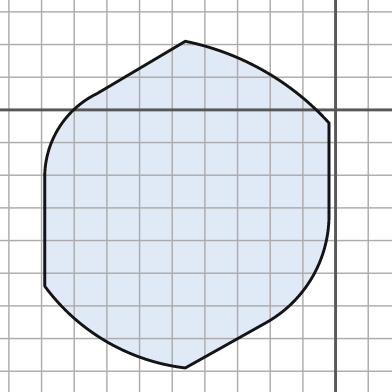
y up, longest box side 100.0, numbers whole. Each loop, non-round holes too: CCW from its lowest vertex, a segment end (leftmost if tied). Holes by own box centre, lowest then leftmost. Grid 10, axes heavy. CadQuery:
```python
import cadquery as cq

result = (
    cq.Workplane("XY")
    .moveTo(-46.0, -79.0)
    .lineTo(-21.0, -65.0)
    .threePointArc((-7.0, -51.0), (-2.0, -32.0))
    .lineTo(-2.0, -4.0)
    .threePointArc((-22.0, 12.0), (-46.0, 21.0))
    .lineTo(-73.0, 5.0)
    .threePointArc((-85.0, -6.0), (-89.0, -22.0))
    .lineTo(-89.0, -54.0)
    .threePointArc((-70.0, -71.0), (-46.0, -79.0))
    .close()
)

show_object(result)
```